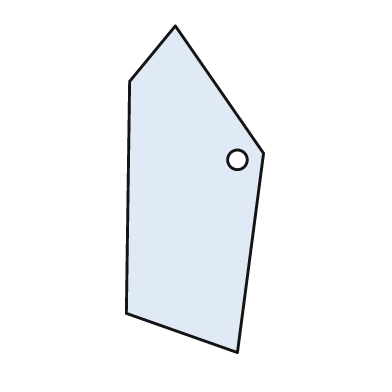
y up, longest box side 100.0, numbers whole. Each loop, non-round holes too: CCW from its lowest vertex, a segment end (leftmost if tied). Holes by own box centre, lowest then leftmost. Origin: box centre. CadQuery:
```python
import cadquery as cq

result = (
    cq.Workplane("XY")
    .moveTo(13.0, -50.0)
    .lineTo(21.0, 11.0)
    .lineTo(-6.0, 50.0)
    .lineTo(-20.0, 33.0)
    .lineTo(-21.0, -38.0)
    .close()
    .moveTo(13.0, 9.0)
    .circle(3.0)
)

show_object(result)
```